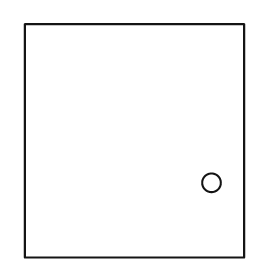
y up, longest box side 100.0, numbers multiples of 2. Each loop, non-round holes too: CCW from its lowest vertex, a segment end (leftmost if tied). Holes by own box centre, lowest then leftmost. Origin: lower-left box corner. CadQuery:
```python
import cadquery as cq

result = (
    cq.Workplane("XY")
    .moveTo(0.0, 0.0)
    .lineTo(94.0, 0.0)
    .lineTo(94.0, 100.0)
    .lineTo(0.0, 100.0)
    .close()
    .moveTo(80.0, 32.0)
    .circle(4.0)
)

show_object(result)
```